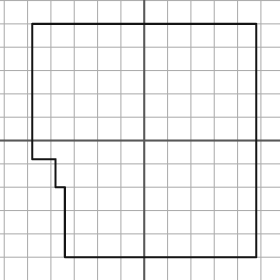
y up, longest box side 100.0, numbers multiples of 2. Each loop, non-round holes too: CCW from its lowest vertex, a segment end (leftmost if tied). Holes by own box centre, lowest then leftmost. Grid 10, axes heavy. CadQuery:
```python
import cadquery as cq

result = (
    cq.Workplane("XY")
    .moveTo(-34.0, -50.0)
    .lineTo(48.0, -50.0)
    .lineTo(48.0, 50.0)
    .lineTo(-48.0, 50.0)
    .lineTo(-48.0, -8.0)
    .lineTo(-38.0, -8.0)
    .lineTo(-38.0, -20.0)
    .lineTo(-34.0, -20.0)
    .close()
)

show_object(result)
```